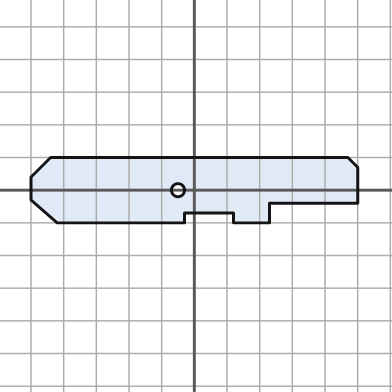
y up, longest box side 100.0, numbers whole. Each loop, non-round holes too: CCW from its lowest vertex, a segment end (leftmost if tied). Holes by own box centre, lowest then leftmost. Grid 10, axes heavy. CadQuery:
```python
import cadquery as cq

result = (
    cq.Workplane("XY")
    .moveTo(-42.0, -10.0)
    .lineTo(-3.0, -10.0)
    .lineTo(-3.0, -7.0)
    .lineTo(12.0, -7.0)
    .lineTo(12.0, -10.0)
    .lineTo(23.0, -10.0)
    .lineTo(23.0, -4.0)
    .lineTo(50.0, -4.0)
    .lineTo(50.0, 7.0)
    .lineTo(47.0, 10.0)
    .lineTo(-44.0, 10.0)
    .lineTo(-50.0, 4.0)
    .lineTo(-50.0, -3.0)
    .close()
    .moveTo(-5.0, 0.0)
    .circle(2.0)
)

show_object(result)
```